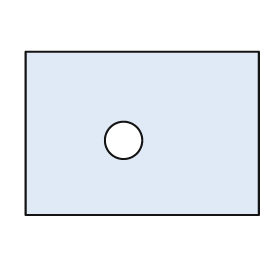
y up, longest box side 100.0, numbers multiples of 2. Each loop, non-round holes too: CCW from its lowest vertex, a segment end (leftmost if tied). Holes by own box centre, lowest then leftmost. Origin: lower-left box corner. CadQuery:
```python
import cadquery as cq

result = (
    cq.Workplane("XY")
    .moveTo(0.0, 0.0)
    .lineTo(100.0, 0.0)
    .lineTo(100.0, 70.0)
    .lineTo(0.0, 70.0)
    .close()
    .moveTo(42.0, 32.0)
    .circle(8.0)
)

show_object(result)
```